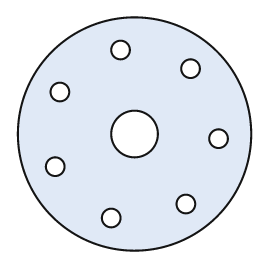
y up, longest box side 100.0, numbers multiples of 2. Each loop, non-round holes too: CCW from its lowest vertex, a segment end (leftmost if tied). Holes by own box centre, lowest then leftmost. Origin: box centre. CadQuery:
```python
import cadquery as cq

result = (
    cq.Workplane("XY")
    .moveTo(0.0, 0.0)
    .circle(50.0)
    .moveTo(-10.0, -36.0)
    .circle(4.0)
    .moveTo(22.0, -30.0)
    .circle(4.0)
    .moveTo(-34.0, -14.0)
    .circle(4.0)
    .moveTo(36.0, -2.0)
    .circle(4.0)
    .moveTo(0.0, 0.0)
    .circle(10.0)
    .moveTo(-32.0, 18.0)
    .circle(4.0)
    .moveTo(24.0, 28.0)
    .circle(4.0)
    .moveTo(-6.0, 36.0)
    .circle(4.0)
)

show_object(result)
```